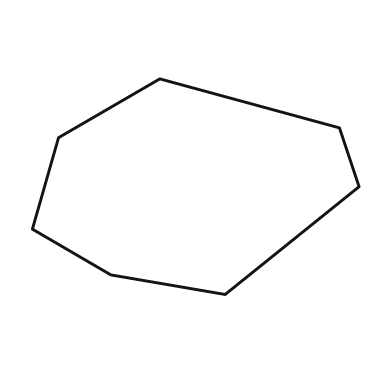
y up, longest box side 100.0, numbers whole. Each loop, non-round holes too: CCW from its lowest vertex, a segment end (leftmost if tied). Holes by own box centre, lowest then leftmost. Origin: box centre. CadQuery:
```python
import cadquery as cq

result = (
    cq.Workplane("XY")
    .moveTo(9.0, -33.0)
    .lineTo(50.0, 0.0)
    .lineTo(44.0, 18.0)
    .lineTo(-11.0, 33.0)
    .lineTo(-42.0, 15.0)
    .lineTo(-50.0, -13.0)
    .lineTo(-26.0, -27.0)
    .close()
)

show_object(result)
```